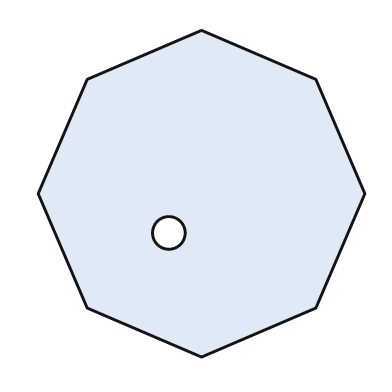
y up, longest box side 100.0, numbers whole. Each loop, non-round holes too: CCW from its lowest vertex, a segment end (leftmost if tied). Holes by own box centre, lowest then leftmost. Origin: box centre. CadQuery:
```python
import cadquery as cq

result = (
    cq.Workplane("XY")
    .moveTo(0.0, -50.0)
    .lineTo(35.0, -35.0)
    .lineTo(50.0, 0.0)
    .lineTo(35.0, 35.0)
    .lineTo(0.0, 50.0)
    .lineTo(-35.0, 35.0)
    .lineTo(-50.0, 0.0)
    .lineTo(-35.0, -35.0)
    .close()
    .moveTo(-10.0, -12.0)
    .circle(5.0)
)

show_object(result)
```